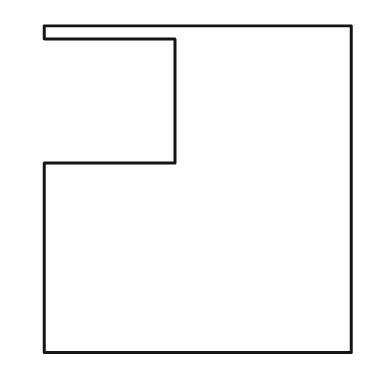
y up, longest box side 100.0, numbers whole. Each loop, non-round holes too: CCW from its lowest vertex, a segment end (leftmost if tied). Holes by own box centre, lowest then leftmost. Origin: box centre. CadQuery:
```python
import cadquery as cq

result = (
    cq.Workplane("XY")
    .moveTo(-47.0, -50.0)
    .lineTo(47.0, -50.0)
    .lineTo(47.0, 50.0)
    .lineTo(-47.0, 50.0)
    .lineTo(-47.0, 46.0)
    .lineTo(-7.0, 46.0)
    .lineTo(-7.0, 8.0)
    .lineTo(-47.0, 8.0)
    .close()
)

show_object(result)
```